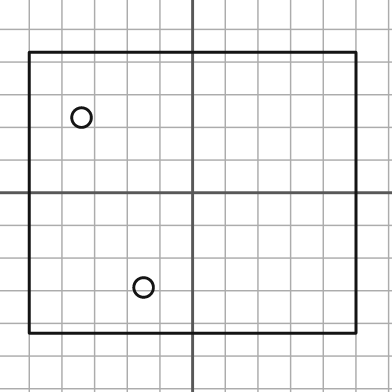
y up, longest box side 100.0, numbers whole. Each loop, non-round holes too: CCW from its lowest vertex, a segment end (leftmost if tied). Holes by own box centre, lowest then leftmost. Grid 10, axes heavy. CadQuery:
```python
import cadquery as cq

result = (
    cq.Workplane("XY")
    .moveTo(-50.0, -43.0)
    .lineTo(50.0, -43.0)
    .lineTo(50.0, 43.0)
    .lineTo(-50.0, 43.0)
    .close()
    .moveTo(-15.0, -29.0)
    .circle(3.0)
    .moveTo(-34.0, 23.0)
    .circle(3.0)
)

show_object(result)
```